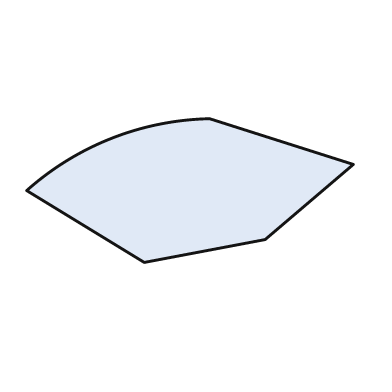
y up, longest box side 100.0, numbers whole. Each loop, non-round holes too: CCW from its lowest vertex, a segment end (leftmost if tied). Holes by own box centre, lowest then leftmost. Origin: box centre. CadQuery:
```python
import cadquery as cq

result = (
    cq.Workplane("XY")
    .moveTo(-14.0, -22.0)
    .lineTo(23.0, -15.0)
    .lineTo(50.0, 8.0)
    .lineTo(6.0, 22.0)
    .threePointArc((-24.0, 16.0), (-50.0, 0.0))
    .close()
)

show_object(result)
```